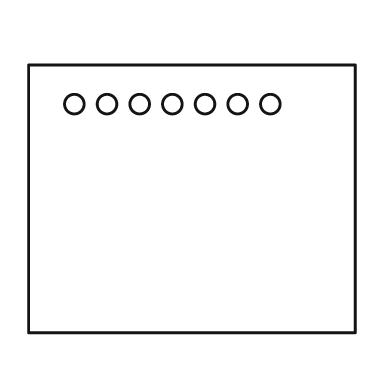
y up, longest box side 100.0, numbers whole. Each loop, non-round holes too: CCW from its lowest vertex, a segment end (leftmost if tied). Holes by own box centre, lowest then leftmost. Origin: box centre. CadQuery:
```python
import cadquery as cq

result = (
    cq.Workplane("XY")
    .moveTo(-50.0, -41.0)
    .lineTo(50.0, -41.0)
    .lineTo(50.0, 41.0)
    .lineTo(-50.0, 41.0)
    .close()
    .moveTo(-36.0, 29.0)
    .circle(3.0)
    .moveTo(-26.0, 29.0)
    .circle(3.0)
    .moveTo(-16.0, 29.0)
    .circle(3.0)
    .moveTo(-6.0, 29.0)
    .circle(3.0)
    .moveTo(4.0, 29.0)
    .circle(3.0)
    .moveTo(14.0, 29.0)
    .circle(3.0)
    .moveTo(24.0, 29.0)
    .circle(3.0)
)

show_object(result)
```